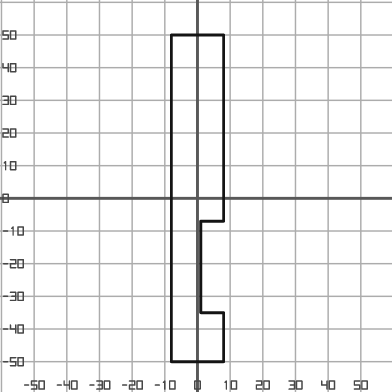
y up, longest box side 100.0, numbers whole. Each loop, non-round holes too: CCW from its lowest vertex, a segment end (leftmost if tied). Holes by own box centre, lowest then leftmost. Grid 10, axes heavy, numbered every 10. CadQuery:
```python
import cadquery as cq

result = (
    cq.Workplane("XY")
    .moveTo(-8.0, -50.0)
    .lineTo(8.0, -50.0)
    .lineTo(8.0, -35.0)
    .lineTo(1.0, -35.0)
    .lineTo(1.0, -7.0)
    .lineTo(8.0, -7.0)
    .lineTo(8.0, 50.0)
    .lineTo(-8.0, 50.0)
    .close()
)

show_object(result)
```